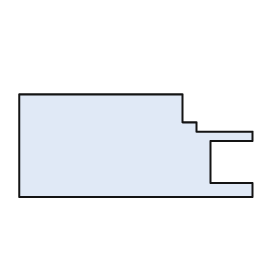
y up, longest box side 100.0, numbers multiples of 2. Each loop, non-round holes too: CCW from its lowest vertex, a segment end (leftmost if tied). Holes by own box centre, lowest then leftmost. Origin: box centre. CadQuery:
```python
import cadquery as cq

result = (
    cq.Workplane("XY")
    .moveTo(-50.0, -22.0)
    .lineTo(50.0, -22.0)
    .lineTo(50.0, -16.0)
    .lineTo(32.0, -16.0)
    .lineTo(32.0, 2.0)
    .lineTo(50.0, 2.0)
    .lineTo(50.0, 6.0)
    .lineTo(26.0, 6.0)
    .lineTo(26.0, 10.0)
    .lineTo(20.0, 10.0)
    .lineTo(20.0, 22.0)
    .lineTo(-50.0, 22.0)
    .close()
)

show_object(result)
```